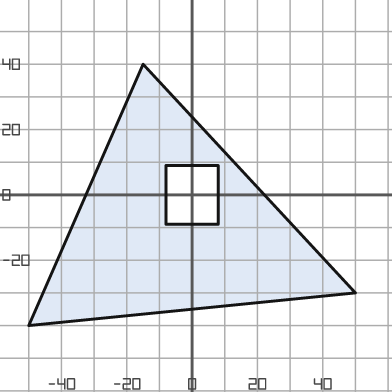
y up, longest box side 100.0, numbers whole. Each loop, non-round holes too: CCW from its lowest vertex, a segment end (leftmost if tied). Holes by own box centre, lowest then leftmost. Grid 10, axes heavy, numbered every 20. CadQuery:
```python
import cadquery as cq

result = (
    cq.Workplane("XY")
    .moveTo(-50.0, -40.0)
    .lineTo(50.0, -30.0)
    .lineTo(-15.0, 40.0)
    .close()
    .moveTo(-8.0, -9.0)
    .lineTo(8.0, -9.0)
    .lineTo(8.0, 9.0)
    .lineTo(-8.0, 9.0)
    .close()
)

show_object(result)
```